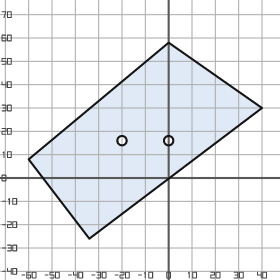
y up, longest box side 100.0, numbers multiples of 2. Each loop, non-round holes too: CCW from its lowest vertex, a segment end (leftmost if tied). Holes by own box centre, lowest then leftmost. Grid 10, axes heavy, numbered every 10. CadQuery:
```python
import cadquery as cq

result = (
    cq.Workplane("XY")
    .moveTo(-34.0, -26.0)
    .lineTo(40.0, 30.0)
    .lineTo(0.0, 58.0)
    .lineTo(-60.0, 8.0)
    .close()
    .moveTo(-20.0, 16.0)
    .circle(2.0)
    .moveTo(0.0, 16.0)
    .circle(2.0)
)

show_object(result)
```